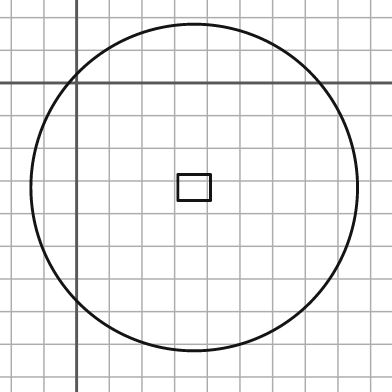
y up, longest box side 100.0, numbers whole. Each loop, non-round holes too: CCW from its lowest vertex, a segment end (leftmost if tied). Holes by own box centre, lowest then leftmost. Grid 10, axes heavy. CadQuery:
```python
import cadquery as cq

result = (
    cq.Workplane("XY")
    .moveTo(36.0, -32.0)
    .circle(50.0)
    .moveTo(31.0, -36.0)
    .lineTo(41.0, -36.0)
    .lineTo(41.0, -28.0)
    .lineTo(31.0, -28.0)
    .close()
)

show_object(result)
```